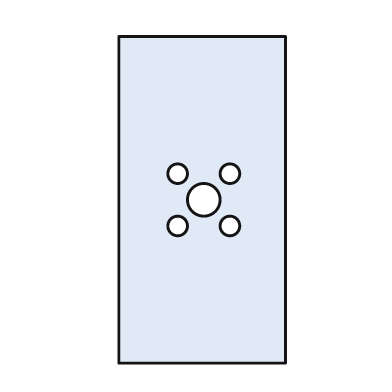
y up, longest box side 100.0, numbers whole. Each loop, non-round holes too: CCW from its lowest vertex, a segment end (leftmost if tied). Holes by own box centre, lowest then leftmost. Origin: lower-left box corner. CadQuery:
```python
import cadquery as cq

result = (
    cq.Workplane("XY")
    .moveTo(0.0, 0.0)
    .lineTo(51.0, 0.0)
    .lineTo(51.0, 100.0)
    .lineTo(0.0, 100.0)
    .close()
    .moveTo(18.0, 42.0)
    .circle(3.0)
    .moveTo(34.0, 42.0)
    .circle(3.0)
    .moveTo(26.0, 50.0)
    .circle(5.0)
    .moveTo(18.0, 58.0)
    .circle(3.0)
    .moveTo(34.0, 58.0)
    .circle(3.0)
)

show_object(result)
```